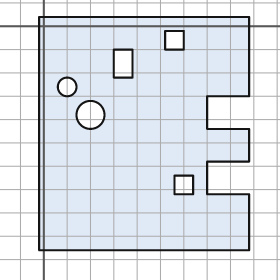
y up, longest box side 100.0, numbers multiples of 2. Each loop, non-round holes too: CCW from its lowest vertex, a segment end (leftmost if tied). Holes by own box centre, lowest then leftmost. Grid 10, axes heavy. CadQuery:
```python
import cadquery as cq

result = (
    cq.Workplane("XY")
    .moveTo(-2.0, -96.0)
    .lineTo(88.0, -96.0)
    .lineTo(88.0, -72.0)
    .lineTo(70.0, -72.0)
    .lineTo(70.0, -58.0)
    .lineTo(88.0, -58.0)
    .lineTo(88.0, -44.0)
    .lineTo(70.0, -44.0)
    .lineTo(70.0, -30.0)
    .lineTo(88.0, -30.0)
    .lineTo(88.0, 4.0)
    .lineTo(-2.0, 4.0)
    .close()
    .moveTo(56.0, -72.0)
    .lineTo(64.0, -72.0)
    .lineTo(64.0, -64.0)
    .lineTo(56.0, -64.0)
    .close()
    .moveTo(20.0, -38.0)
    .circle(6.0)
    .moveTo(10.0, -26.0)
    .circle(4.0)
    .moveTo(30.0, -22.0)
    .lineTo(38.0, -22.0)
    .lineTo(38.0, -10.0)
    .lineTo(30.0, -10.0)
    .close()
    .moveTo(52.0, -10.0)
    .lineTo(60.0, -10.0)
    .lineTo(60.0, -2.0)
    .lineTo(52.0, -2.0)
    .close()
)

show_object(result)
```